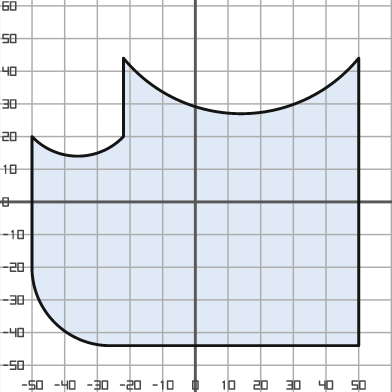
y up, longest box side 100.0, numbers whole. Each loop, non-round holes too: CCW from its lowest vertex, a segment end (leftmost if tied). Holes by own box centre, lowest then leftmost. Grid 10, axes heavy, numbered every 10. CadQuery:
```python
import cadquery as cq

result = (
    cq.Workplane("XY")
    .moveTo(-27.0, -44.0)
    .lineTo(50.0, -44.0)
    .lineTo(50.0, 44.0)
    .threePointArc((14.0, 27.0), (-22.0, 44.0))
    .lineTo(-22.0, 20.0)
    .threePointArc((-36.0, 14.0), (-50.0, 20.0))
    .lineTo(-50.0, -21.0)
    .threePointArc((-43.0, -37.0), (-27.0, -44.0))
    .close()
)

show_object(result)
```